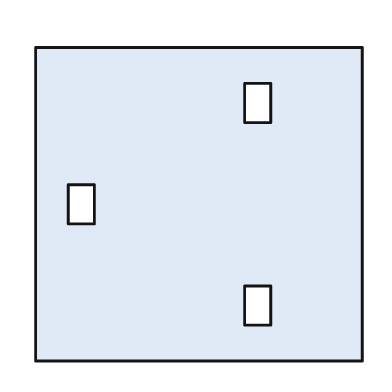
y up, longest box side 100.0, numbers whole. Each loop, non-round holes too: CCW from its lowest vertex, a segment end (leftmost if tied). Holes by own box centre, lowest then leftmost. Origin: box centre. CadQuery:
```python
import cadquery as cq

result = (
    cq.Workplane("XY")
    .moveTo(-50.0, -48.0)
    .lineTo(50.0, -48.0)
    .lineTo(50.0, 48.0)
    .lineTo(-50.0, 48.0)
    .close()
    .moveTo(14.0, -37.0)
    .lineTo(22.0, -37.0)
    .lineTo(22.0, -25.0)
    .lineTo(14.0, -25.0)
    .close()
    .moveTo(-40.0, -6.0)
    .lineTo(-32.0, -6.0)
    .lineTo(-32.0, 6.0)
    .lineTo(-40.0, 6.0)
    .close()
    .moveTo(14.0, 25.0)
    .lineTo(22.0, 25.0)
    .lineTo(22.0, 37.0)
    .lineTo(14.0, 37.0)
    .close()
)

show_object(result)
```